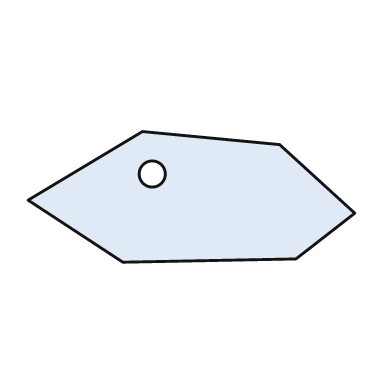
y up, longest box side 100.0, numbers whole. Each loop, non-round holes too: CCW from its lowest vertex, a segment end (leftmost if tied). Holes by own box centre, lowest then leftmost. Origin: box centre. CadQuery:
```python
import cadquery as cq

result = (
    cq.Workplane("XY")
    .moveTo(-21.0, -20.0)
    .lineTo(32.0, -19.0)
    .lineTo(50.0, -5.0)
    .lineTo(27.0, 16.0)
    .lineTo(-15.0, 20.0)
    .lineTo(-50.0, -1.0)
    .close()
    .moveTo(-12.0, 7.0)
    .circle(4.0)
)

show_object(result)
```